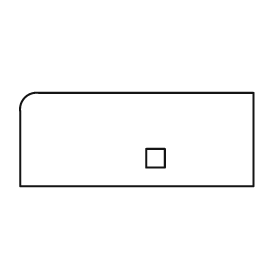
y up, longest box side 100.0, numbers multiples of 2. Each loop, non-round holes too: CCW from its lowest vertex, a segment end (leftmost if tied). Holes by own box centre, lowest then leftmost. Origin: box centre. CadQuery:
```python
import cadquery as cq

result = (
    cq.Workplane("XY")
    .moveTo(-50.0, -20.0)
    .lineTo(50.0, -20.0)
    .lineTo(50.0, 20.0)
    .lineTo(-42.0, 20.0)
    .threePointArc((-48.0, 18.0), (-50.0, 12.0))
    .close()
    .moveTo(4.0, -12.0)
    .lineTo(12.0, -12.0)
    .lineTo(12.0, -4.0)
    .lineTo(4.0, -4.0)
    .close()
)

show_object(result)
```